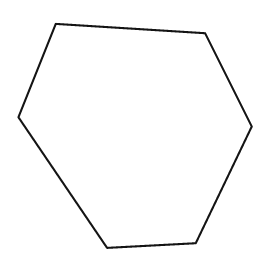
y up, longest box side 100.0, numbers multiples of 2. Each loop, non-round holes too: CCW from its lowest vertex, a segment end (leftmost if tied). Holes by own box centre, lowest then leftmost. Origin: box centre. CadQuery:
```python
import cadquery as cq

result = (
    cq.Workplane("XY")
    .moveTo(-12.0, -48.0)
    .lineTo(26.0, -46.0)
    .lineTo(50.0, 4.0)
    .lineTo(30.0, 44.0)
    .lineTo(-34.0, 48.0)
    .lineTo(-50.0, 8.0)
    .close()
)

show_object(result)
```